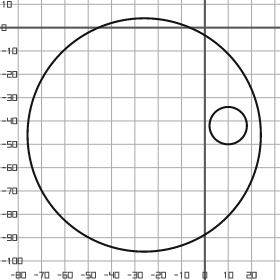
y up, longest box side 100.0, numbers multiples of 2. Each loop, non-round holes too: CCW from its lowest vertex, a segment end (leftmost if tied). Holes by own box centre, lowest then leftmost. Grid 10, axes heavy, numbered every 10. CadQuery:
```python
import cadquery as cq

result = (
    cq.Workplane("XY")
    .moveTo(-26.0, -46.0)
    .circle(50.0)
    .moveTo(10.0, -42.0)
    .circle(8.0)
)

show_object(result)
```